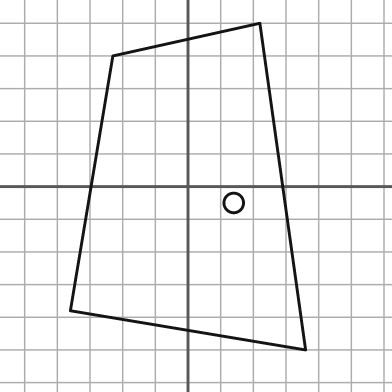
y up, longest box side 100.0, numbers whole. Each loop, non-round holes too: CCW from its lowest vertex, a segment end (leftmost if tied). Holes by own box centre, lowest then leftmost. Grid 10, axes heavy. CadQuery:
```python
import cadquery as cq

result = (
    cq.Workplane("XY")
    .moveTo(36.0, -50.0)
    .lineTo(22.0, 50.0)
    .lineTo(-23.0, 40.0)
    .lineTo(-36.0, -38.0)
    .close()
    .moveTo(14.0, -5.0)
    .circle(3.0)
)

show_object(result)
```